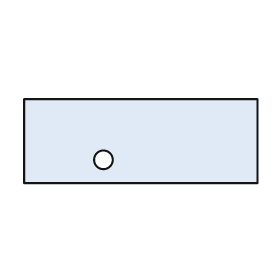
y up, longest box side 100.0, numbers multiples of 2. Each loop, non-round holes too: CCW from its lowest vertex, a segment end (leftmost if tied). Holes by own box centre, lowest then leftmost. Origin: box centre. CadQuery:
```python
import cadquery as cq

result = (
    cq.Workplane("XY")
    .moveTo(-50.0, -18.0)
    .lineTo(50.0, -18.0)
    .lineTo(50.0, 18.0)
    .lineTo(-50.0, 18.0)
    .close()
    .moveTo(-16.0, -8.0)
    .circle(4.0)
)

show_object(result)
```